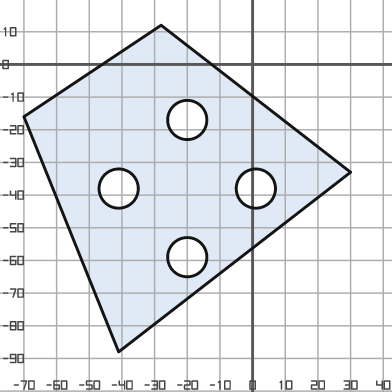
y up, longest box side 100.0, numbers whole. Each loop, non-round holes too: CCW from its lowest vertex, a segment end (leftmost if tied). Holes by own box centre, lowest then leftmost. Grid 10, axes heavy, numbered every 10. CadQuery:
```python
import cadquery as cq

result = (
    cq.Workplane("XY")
    .moveTo(-41.0, -88.0)
    .lineTo(30.0, -33.0)
    .lineTo(-28.0, 12.0)
    .lineTo(-70.0, -16.0)
    .close()
    .moveTo(-20.0, -59.0)
    .circle(6.0)
    .moveTo(-41.0, -38.0)
    .circle(6.0)
    .moveTo(1.0, -38.0)
    .circle(6.0)
    .moveTo(-20.0, -17.0)
    .circle(6.0)
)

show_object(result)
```